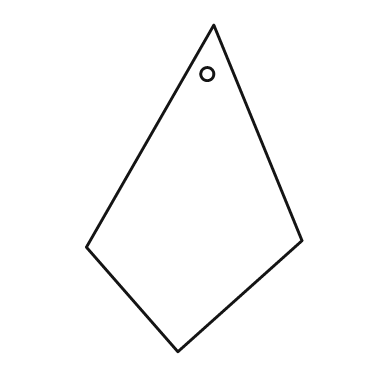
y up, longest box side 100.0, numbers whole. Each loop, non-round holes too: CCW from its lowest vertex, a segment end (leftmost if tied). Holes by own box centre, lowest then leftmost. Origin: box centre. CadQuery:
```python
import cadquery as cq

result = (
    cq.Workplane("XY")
    .moveTo(-5.0, -50.0)
    .lineTo(33.0, -16.0)
    .lineTo(6.0, 50.0)
    .lineTo(-33.0, -18.0)
    .close()
    .moveTo(4.0, 35.0)
    .circle(2.0)
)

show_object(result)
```